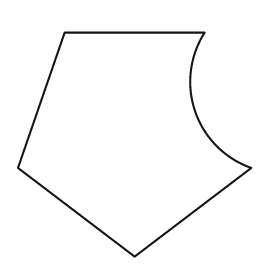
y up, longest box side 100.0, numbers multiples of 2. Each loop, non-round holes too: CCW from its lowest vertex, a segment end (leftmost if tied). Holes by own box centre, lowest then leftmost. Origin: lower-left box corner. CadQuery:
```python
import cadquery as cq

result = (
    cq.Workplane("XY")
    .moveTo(50.0, 0.0)
    .lineTo(100.0, 38.0)
    .threePointArc((76.0, 62.0), (80.0, 96.0))
    .lineTo(20.0, 96.0)
    .lineTo(0.0, 38.0)
    .close()
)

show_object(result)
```